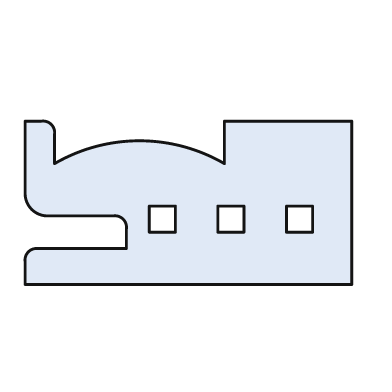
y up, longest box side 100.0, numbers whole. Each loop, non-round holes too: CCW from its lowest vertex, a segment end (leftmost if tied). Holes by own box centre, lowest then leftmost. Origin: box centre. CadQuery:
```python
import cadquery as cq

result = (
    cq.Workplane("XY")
    .moveTo(-50.0, -25.0)
    .lineTo(50.0, -25.0)
    .lineTo(50.0, 25.0)
    .lineTo(11.0, 25.0)
    .lineTo(11.0, 12.0)
    .threePointArc((-15.0, 19.0), (-41.0, 12.0))
    .lineTo(-41.0, 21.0)
    .threePointArc((-42.0, 24.0), (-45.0, 25.0))
    .lineTo(-50.0, 25.0)
    .lineTo(-50.0, 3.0)
    .threePointArc((-48.0, -2.0), (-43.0, -4.0))
    .lineTo(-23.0, -4.0)
    .threePointArc((-20.0, -5.0), (-19.0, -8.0))
    .lineTo(-19.0, -14.0)
    .lineTo(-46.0, -14.0)
    .threePointArc((-49.0, -15.0), (-50.0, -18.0))
    .close()
    .moveTo(-12.0, -9.0)
    .lineTo(-4.0, -9.0)
    .lineTo(-4.0, -1.0)
    .lineTo(-12.0, -1.0)
    .close()
    .moveTo(9.0, -9.0)
    .lineTo(17.0, -9.0)
    .lineTo(17.0, -1.0)
    .lineTo(9.0, -1.0)
    .close()
    .moveTo(30.0, -9.0)
    .lineTo(38.0, -9.0)
    .lineTo(38.0, -1.0)
    .lineTo(30.0, -1.0)
    .close()
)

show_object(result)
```